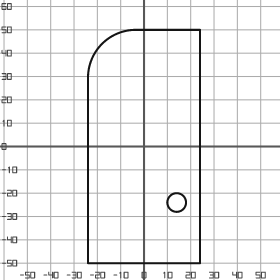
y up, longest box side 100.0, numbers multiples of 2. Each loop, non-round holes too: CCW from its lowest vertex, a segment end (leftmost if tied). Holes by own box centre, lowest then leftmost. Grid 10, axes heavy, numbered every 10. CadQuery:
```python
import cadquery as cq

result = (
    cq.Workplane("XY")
    .moveTo(-24.0, -50.0)
    .lineTo(24.0, -50.0)
    .lineTo(24.0, 50.0)
    .lineTo(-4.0, 50.0)
    .threePointArc((-18.0, 44.0), (-24.0, 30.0))
    .close()
    .moveTo(14.0, -24.0)
    .circle(4.0)
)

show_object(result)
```